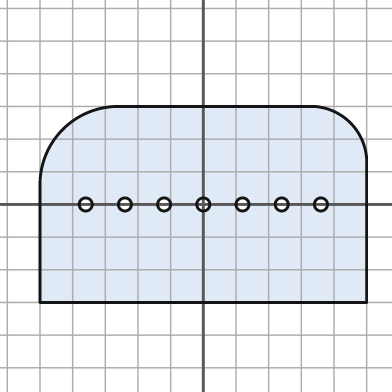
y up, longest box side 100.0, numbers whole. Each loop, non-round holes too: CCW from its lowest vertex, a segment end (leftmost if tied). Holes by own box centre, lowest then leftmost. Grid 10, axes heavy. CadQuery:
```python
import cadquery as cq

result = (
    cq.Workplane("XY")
    .moveTo(-50.0, -30.0)
    .lineTo(50.0, -30.0)
    .lineTo(50.0, 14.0)
    .threePointArc((45.0, 25.0), (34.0, 30.0))
    .lineTo(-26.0, 30.0)
    .threePointArc((-43.0, 23.0), (-50.0, 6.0))
    .close()
    .moveTo(-36.0, 0.0)
    .circle(2.0)
    .moveTo(-24.0, 0.0)
    .circle(2.0)
    .moveTo(-12.0, 0.0)
    .circle(2.0)
    .moveTo(0.0, 0.0)
    .circle(2.0)
    .moveTo(12.0, 0.0)
    .circle(2.0)
    .moveTo(24.0, 0.0)
    .circle(2.0)
    .moveTo(36.0, 0.0)
    .circle(2.0)
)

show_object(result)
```